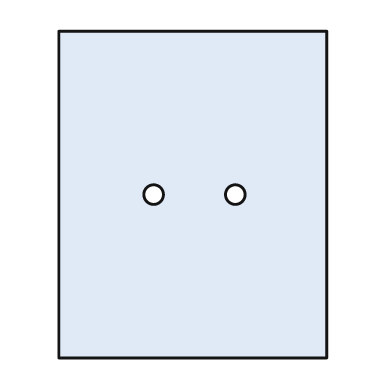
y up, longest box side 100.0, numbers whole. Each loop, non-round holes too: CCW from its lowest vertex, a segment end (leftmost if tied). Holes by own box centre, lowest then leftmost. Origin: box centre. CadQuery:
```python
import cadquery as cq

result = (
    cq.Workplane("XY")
    .moveTo(-41.0, -50.0)
    .lineTo(41.0, -50.0)
    .lineTo(41.0, 50.0)
    .lineTo(-41.0, 50.0)
    .close()
    .moveTo(-12.0, 0.0)
    .circle(3.0)
    .moveTo(13.0, 0.0)
    .circle(3.0)
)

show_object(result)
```